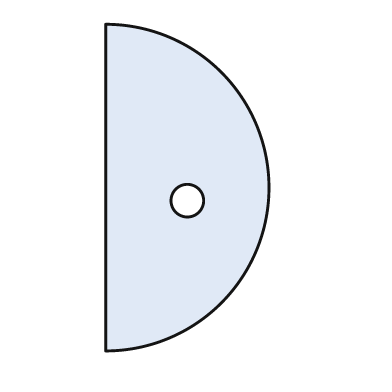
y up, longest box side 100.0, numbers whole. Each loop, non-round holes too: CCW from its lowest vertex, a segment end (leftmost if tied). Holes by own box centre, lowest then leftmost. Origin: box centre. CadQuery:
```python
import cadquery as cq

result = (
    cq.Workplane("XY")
    .moveTo(-25.0, -50.0)
    .threePointArc((25.0, 0.0), (-25.0, 50.0))
    .close()
    .moveTo(0.0, -4.0)
    .circle(5.0)
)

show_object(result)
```